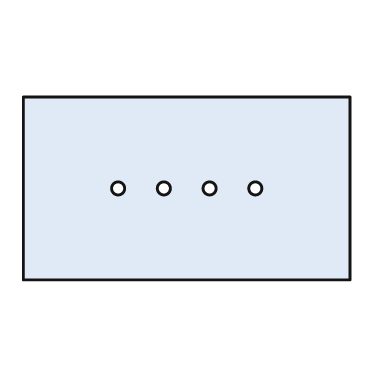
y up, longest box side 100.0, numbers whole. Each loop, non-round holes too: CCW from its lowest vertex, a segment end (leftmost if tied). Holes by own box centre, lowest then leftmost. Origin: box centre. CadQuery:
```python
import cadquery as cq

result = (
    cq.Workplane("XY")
    .moveTo(-50.0, -28.0)
    .lineTo(50.0, -28.0)
    .lineTo(50.0, 28.0)
    .lineTo(-50.0, 28.0)
    .close()
    .moveTo(-21.0, 0.0)
    .circle(2.0)
    .moveTo(-7.0, 0.0)
    .circle(2.0)
    .moveTo(7.0, 0.0)
    .circle(2.0)
    .moveTo(21.0, 0.0)
    .circle(2.0)
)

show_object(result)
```